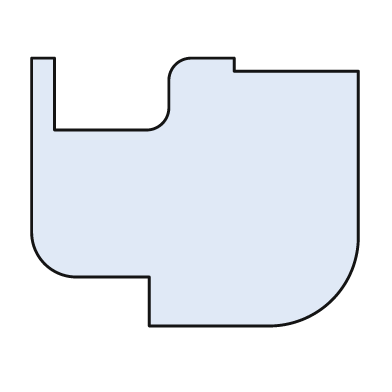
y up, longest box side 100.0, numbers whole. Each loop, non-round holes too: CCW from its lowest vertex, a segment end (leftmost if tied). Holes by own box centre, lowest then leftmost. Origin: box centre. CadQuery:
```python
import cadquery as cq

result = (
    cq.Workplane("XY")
    .moveTo(-14.0, -41.0)
    .lineTo(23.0, -41.0)
    .threePointArc((42.0, -33.0), (50.0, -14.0))
    .lineTo(50.0, 37.0)
    .lineTo(12.0, 37.0)
    .lineTo(12.0, 41.0)
    .lineTo(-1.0, 41.0)
    .threePointArc((-6.0, 39.0), (-8.0, 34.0))
    .lineTo(-8.0, 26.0)
    .threePointArc((-10.0, 21.0), (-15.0, 19.0))
    .lineTo(-43.0, 19.0)
    .lineTo(-43.0, 41.0)
    .lineTo(-50.0, 41.0)
    .lineTo(-50.0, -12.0)
    .threePointArc((-46.0, -22.0), (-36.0, -26.0))
    .lineTo(-14.0, -26.0)
    .close()
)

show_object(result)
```